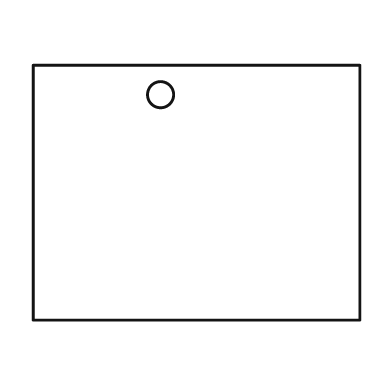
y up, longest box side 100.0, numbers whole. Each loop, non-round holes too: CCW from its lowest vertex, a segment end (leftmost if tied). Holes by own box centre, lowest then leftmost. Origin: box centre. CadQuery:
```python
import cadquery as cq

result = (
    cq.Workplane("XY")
    .moveTo(-50.0, -39.0)
    .lineTo(50.0, -39.0)
    .lineTo(50.0, 39.0)
    .lineTo(-50.0, 39.0)
    .close()
    .moveTo(-11.0, 30.0)
    .circle(4.0)
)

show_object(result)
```